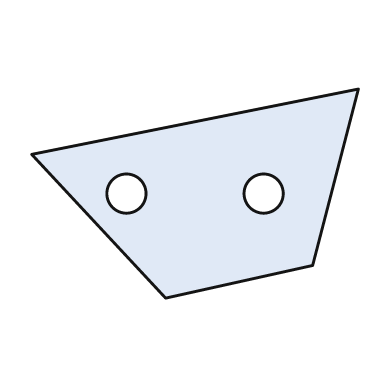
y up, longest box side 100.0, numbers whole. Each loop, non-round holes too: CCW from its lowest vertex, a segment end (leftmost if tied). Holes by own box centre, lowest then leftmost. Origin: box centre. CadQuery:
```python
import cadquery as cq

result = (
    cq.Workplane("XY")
    .moveTo(-9.0, -32.0)
    .lineTo(36.0, -22.0)
    .lineTo(50.0, 32.0)
    .lineTo(-50.0, 12.0)
    .close()
    .moveTo(-21.0, 0.0)
    .circle(6.0)
    .moveTo(21.0, 0.0)
    .circle(6.0)
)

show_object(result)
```